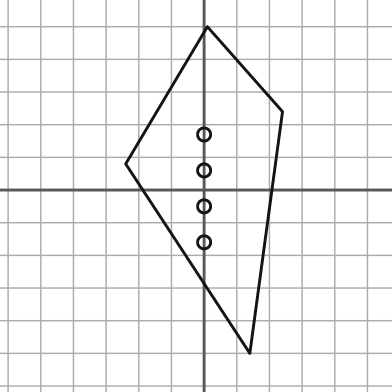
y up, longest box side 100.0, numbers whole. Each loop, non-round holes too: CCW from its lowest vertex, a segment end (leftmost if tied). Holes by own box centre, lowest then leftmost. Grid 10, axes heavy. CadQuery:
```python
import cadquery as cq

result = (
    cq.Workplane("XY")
    .moveTo(14.0, -50.0)
    .lineTo(24.0, 24.0)
    .lineTo(1.0, 50.0)
    .lineTo(-24.0, 8.0)
    .close()
    .moveTo(0.0, -16.0)
    .circle(2.0)
    .moveTo(0.0, -5.0)
    .circle(2.0)
    .moveTo(0.0, 6.0)
    .circle(2.0)
    .moveTo(0.0, 17.0)
    .circle(2.0)
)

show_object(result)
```